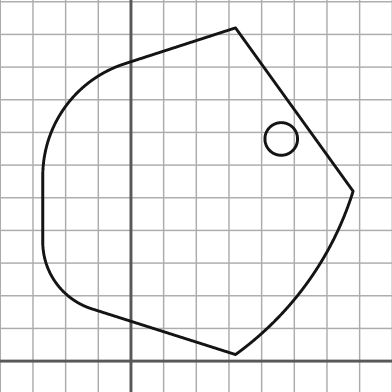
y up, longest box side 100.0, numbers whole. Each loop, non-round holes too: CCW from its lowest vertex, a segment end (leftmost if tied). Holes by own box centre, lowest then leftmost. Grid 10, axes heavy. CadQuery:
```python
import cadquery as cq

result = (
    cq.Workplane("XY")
    .moveTo(32.0, 2.0)
    .threePointArc((54.0, 24.0), (68.0, 52.0))
    .lineTo(32.0, 102.0)
    .lineTo(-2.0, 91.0)
    .threePointArc((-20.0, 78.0), (-27.0, 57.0))
    .lineTo(-27.0, 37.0)
    .threePointArc((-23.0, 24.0), (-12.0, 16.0))
    .close()
    .moveTo(46.0, 68.0)
    .circle(5.0)
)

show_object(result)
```